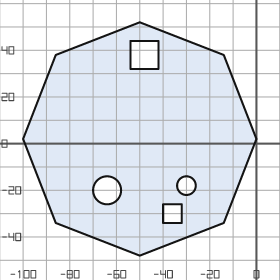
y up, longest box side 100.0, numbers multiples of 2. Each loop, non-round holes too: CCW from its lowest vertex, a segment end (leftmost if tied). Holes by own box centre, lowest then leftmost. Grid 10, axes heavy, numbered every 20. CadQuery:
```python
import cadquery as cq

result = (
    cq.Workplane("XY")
    .moveTo(-50.0, -48.0)
    .lineTo(-14.0, -34.0)
    .lineTo(0.0, 2.0)
    .lineTo(-14.0, 38.0)
    .lineTo(-50.0, 52.0)
    .lineTo(-86.0, 38.0)
    .lineTo(-100.0, 2.0)
    .lineTo(-86.0, -34.0)
    .close()
    .moveTo(-40.0, -34.0)
    .lineTo(-32.0, -34.0)
    .lineTo(-32.0, -26.0)
    .lineTo(-40.0, -26.0)
    .close()
    .moveTo(-64.0, -20.0)
    .circle(6.0)
    .moveTo(-30.0, -18.0)
    .circle(4.0)
    .moveTo(-54.0, 32.0)
    .lineTo(-42.0, 32.0)
    .lineTo(-42.0, 44.0)
    .lineTo(-54.0, 44.0)
    .close()
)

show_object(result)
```